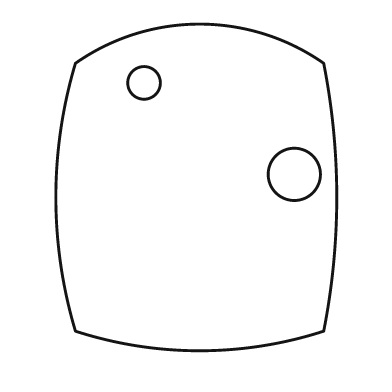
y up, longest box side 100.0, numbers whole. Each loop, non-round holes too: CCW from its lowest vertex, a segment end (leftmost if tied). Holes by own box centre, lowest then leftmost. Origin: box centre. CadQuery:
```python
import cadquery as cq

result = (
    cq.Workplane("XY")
    .moveTo(-37.0, -44.0)
    .threePointArc((1.0, -50.0), (39.0, -44.0))
    .threePointArc((43.0, -3.0), (39.0, 38.0))
    .threePointArc((1.0, 50.0), (-37.0, 38.0))
    .threePointArc((-43.0, -3.0), (-37.0, -44.0))
    .close()
    .moveTo(30.0, 4.0)
    .circle(8.0)
    .moveTo(-16.0, 32.0)
    .circle(5.0)
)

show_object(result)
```